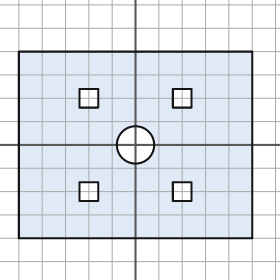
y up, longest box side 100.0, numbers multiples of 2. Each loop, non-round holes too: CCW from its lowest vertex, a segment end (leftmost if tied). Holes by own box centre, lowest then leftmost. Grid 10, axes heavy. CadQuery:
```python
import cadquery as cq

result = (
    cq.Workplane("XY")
    .moveTo(-50.0, -40.0)
    .lineTo(50.0, -40.0)
    .lineTo(50.0, 40.0)
    .lineTo(-50.0, 40.0)
    .close()
    .moveTo(-24.0, -24.0)
    .lineTo(-16.0, -24.0)
    .lineTo(-16.0, -16.0)
    .lineTo(-24.0, -16.0)
    .close()
    .moveTo(16.0, -24.0)
    .lineTo(24.0, -24.0)
    .lineTo(24.0, -16.0)
    .lineTo(16.0, -16.0)
    .close()
    .moveTo(0.0, 0.0)
    .circle(8.0)
    .moveTo(-24.0, 16.0)
    .lineTo(-16.0, 16.0)
    .lineTo(-16.0, 24.0)
    .lineTo(-24.0, 24.0)
    .close()
    .moveTo(16.0, 16.0)
    .lineTo(24.0, 16.0)
    .lineTo(24.0, 24.0)
    .lineTo(16.0, 24.0)
    .close()
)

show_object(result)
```